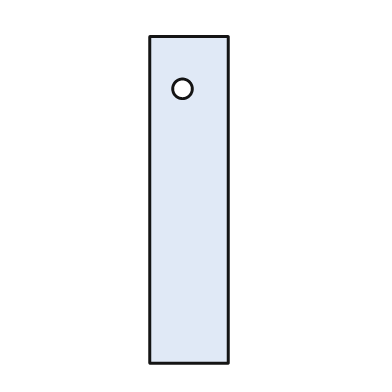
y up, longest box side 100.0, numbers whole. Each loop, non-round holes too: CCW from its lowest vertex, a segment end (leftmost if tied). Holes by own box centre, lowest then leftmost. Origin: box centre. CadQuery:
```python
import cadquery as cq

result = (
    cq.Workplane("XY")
    .moveTo(-12.0, -50.0)
    .lineTo(12.0, -50.0)
    .lineTo(12.0, 50.0)
    .lineTo(-12.0, 50.0)
    .close()
    .moveTo(-2.0, 34.0)
    .circle(3.0)
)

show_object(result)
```